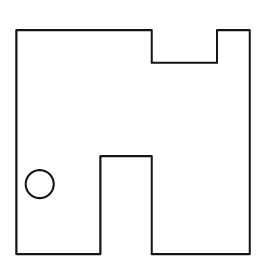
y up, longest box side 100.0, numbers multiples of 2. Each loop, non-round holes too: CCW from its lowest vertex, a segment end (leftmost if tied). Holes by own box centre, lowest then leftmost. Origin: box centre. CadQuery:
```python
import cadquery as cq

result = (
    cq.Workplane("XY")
    .moveTo(-50.0, -48.0)
    .lineTo(-14.0, -48.0)
    .lineTo(-14.0, -6.0)
    .lineTo(8.0, -6.0)
    .lineTo(8.0, -48.0)
    .lineTo(50.0, -48.0)
    .lineTo(50.0, 48.0)
    .lineTo(36.0, 48.0)
    .lineTo(36.0, 34.0)
    .lineTo(8.0, 34.0)
    .lineTo(8.0, 48.0)
    .lineTo(-50.0, 48.0)
    .close()
    .moveTo(-40.0, -18.0)
    .circle(6.0)
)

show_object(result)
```